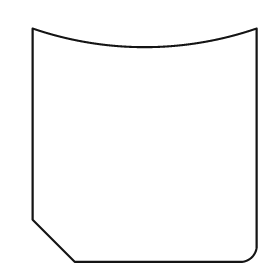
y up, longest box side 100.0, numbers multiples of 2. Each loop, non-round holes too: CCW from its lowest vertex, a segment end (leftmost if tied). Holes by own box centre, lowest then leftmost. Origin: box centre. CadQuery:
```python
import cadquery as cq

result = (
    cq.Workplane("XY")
    .moveTo(-30.0, -50.0)
    .lineTo(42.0, -50.0)
    .threePointArc((46.0, -48.0), (48.0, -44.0))
    .lineTo(48.0, 50.0)
    .threePointArc((0.0, 42.0), (-48.0, 50.0))
    .lineTo(-48.0, -32.0)
    .close()
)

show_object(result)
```